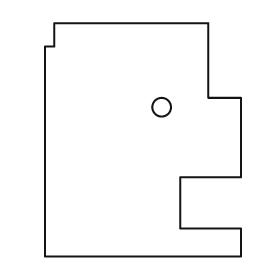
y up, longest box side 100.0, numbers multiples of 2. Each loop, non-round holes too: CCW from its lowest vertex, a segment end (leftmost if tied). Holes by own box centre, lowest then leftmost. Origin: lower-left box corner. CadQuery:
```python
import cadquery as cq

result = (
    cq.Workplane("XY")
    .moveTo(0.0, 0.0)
    .lineTo(84.0, 0.0)
    .lineTo(84.0, 12.0)
    .lineTo(58.0, 12.0)
    .lineTo(58.0, 34.0)
    .lineTo(84.0, 34.0)
    .lineTo(84.0, 68.0)
    .lineTo(70.0, 68.0)
    .lineTo(70.0, 100.0)
    .lineTo(4.0, 100.0)
    .lineTo(4.0, 90.0)
    .lineTo(0.0, 90.0)
    .close()
    .moveTo(50.0, 64.0)
    .circle(4.0)
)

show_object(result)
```